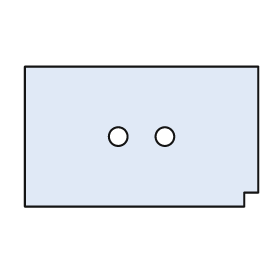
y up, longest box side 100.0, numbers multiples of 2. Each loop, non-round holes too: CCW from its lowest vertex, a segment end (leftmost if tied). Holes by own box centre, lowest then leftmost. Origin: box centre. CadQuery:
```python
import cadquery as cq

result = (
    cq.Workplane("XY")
    .moveTo(-50.0, -30.0)
    .lineTo(44.0, -30.0)
    .lineTo(44.0, -24.0)
    .lineTo(50.0, -24.0)
    .lineTo(50.0, 30.0)
    .lineTo(-50.0, 30.0)
    .close()
    .moveTo(-10.0, 0.0)
    .circle(4.0)
    .moveTo(10.0, 0.0)
    .circle(4.0)
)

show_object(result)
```